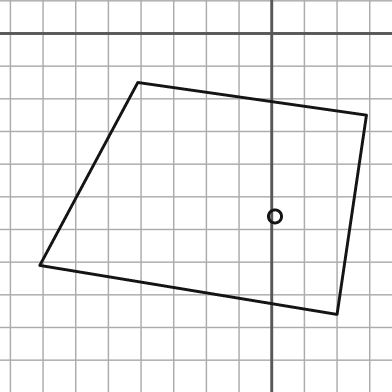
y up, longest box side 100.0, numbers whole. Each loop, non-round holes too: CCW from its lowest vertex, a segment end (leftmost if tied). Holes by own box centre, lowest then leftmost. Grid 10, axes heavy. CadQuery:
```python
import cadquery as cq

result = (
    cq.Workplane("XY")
    .moveTo(20.0, -86.0)
    .lineTo(29.0, -25.0)
    .lineTo(-41.0, -15.0)
    .lineTo(-71.0, -71.0)
    .close()
    .moveTo(1.0, -56.0)
    .circle(2.0)
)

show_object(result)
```